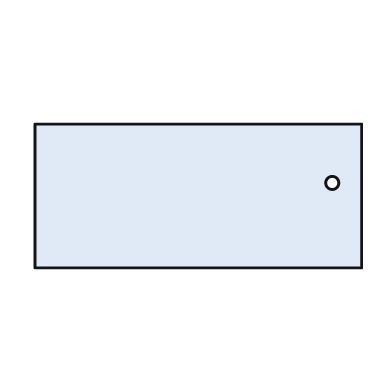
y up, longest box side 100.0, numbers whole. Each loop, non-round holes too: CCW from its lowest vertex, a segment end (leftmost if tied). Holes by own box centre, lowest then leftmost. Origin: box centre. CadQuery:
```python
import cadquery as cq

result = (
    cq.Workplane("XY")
    .moveTo(-50.0, -22.0)
    .lineTo(50.0, -22.0)
    .lineTo(50.0, 22.0)
    .lineTo(-50.0, 22.0)
    .close()
    .moveTo(41.0, 4.0)
    .circle(2.0)
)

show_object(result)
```